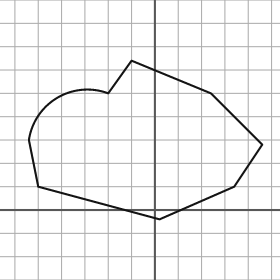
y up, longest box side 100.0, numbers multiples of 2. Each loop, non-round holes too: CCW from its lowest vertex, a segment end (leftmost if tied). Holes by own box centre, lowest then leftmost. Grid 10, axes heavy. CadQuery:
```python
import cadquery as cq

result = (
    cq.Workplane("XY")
    .moveTo(2.0, -4.0)
    .lineTo(34.0, 10.0)
    .lineTo(46.0, 28.0)
    .lineTo(24.0, 50.0)
    .lineTo(-10.0, 64.0)
    .lineTo(-20.0, 50.0)
    .threePointArc((-42.0, 48.0), (-54.0, 30.0))
    .lineTo(-50.0, 10.0)
    .close()
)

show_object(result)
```